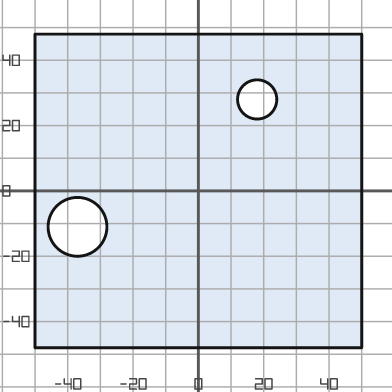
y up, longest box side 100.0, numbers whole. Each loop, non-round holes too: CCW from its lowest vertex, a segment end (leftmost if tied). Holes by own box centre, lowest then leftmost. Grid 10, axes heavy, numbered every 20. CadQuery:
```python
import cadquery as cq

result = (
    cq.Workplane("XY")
    .moveTo(-50.0, -48.0)
    .lineTo(50.0, -48.0)
    .lineTo(50.0, 48.0)
    .lineTo(-50.0, 48.0)
    .close()
    .moveTo(-37.0, -11.0)
    .circle(9.0)
    .moveTo(18.0, 28.0)
    .circle(6.0)
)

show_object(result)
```